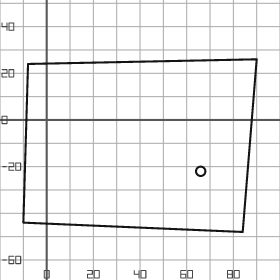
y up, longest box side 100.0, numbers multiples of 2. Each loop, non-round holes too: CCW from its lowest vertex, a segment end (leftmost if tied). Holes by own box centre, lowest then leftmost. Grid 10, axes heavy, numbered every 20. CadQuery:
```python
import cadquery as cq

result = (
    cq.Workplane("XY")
    .moveTo(84.0, -48.0)
    .lineTo(90.0, 26.0)
    .lineTo(-8.0, 24.0)
    .lineTo(-10.0, -44.0)
    .close()
    .moveTo(66.0, -22.0)
    .circle(2.0)
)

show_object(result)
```